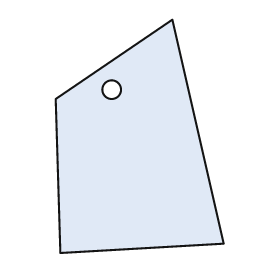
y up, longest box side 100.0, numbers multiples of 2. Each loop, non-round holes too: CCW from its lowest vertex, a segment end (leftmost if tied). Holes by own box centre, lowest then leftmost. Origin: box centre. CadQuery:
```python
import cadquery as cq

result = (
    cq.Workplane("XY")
    .moveTo(-34.0, -50.0)
    .lineTo(36.0, -46.0)
    .lineTo(14.0, 50.0)
    .lineTo(-36.0, 16.0)
    .close()
    .moveTo(-12.0, 20.0)
    .circle(4.0)
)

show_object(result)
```